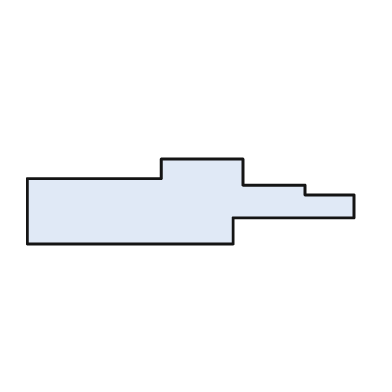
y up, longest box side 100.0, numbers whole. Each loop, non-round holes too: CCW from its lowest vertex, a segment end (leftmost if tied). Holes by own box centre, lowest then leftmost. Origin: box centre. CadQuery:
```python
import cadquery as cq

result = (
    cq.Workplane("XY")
    .moveTo(-50.0, -13.0)
    .lineTo(13.0, -13.0)
    .lineTo(13.0, -5.0)
    .lineTo(50.0, -5.0)
    .lineTo(50.0, 2.0)
    .lineTo(35.0, 2.0)
    .lineTo(35.0, 5.0)
    .lineTo(16.0, 5.0)
    .lineTo(16.0, 13.0)
    .lineTo(-9.0, 13.0)
    .lineTo(-9.0, 7.0)
    .lineTo(-50.0, 7.0)
    .close()
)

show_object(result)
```